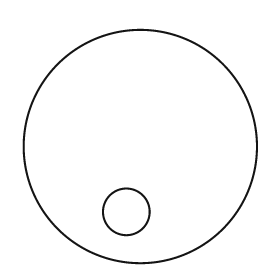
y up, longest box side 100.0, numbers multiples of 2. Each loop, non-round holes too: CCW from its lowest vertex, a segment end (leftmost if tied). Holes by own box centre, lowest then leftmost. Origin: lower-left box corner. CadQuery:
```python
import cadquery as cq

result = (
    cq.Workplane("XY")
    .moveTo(50.0, 50.0)
    .circle(50.0)
    .moveTo(44.0, 22.0)
    .circle(10.0)
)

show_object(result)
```